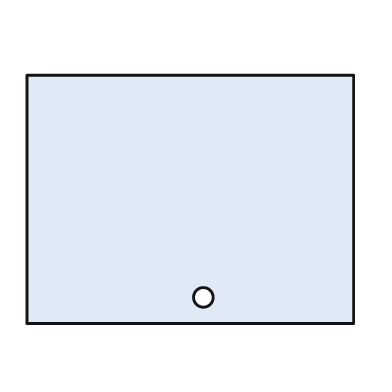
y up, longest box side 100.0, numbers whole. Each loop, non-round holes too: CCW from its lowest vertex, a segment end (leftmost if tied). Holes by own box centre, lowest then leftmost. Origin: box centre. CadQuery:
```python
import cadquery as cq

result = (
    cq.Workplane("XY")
    .moveTo(-50.0, -38.0)
    .lineTo(50.0, -38.0)
    .lineTo(50.0, 38.0)
    .lineTo(-50.0, 38.0)
    .close()
    .moveTo(4.0, -30.0)
    .circle(3.0)
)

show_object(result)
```